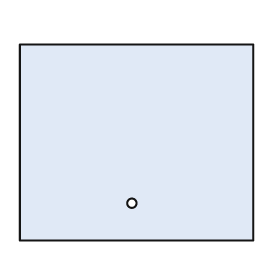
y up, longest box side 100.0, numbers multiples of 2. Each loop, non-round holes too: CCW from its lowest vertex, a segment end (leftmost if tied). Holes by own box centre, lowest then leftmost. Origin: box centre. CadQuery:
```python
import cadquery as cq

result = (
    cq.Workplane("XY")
    .moveTo(-50.0, -42.0)
    .lineTo(50.0, -42.0)
    .lineTo(50.0, 42.0)
    .lineTo(-50.0, 42.0)
    .close()
    .moveTo(-2.0, -26.0)
    .circle(2.0)
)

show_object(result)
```